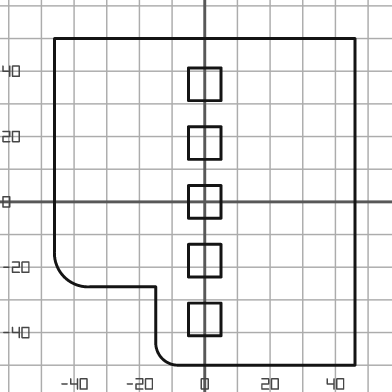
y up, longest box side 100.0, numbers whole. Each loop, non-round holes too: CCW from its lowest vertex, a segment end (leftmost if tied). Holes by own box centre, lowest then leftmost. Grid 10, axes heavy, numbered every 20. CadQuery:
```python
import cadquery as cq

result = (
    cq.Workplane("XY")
    .moveTo(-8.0, -50.0)
    .lineTo(46.0, -50.0)
    .lineTo(46.0, 50.0)
    .lineTo(-46.0, 50.0)
    .lineTo(-46.0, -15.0)
    .threePointArc((-43.0, -23.0), (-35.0, -26.0))
    .lineTo(-15.0, -26.0)
    .lineTo(-15.0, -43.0)
    .threePointArc((-13.0, -48.0), (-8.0, -50.0))
    .close()
    .moveTo(-5.0, -41.0)
    .lineTo(5.0, -41.0)
    .lineTo(5.0, -31.0)
    .lineTo(-5.0, -31.0)
    .close()
    .moveTo(-5.0, -23.0)
    .lineTo(5.0, -23.0)
    .lineTo(5.0, -13.0)
    .lineTo(-5.0, -13.0)
    .close()
    .moveTo(-5.0, -5.0)
    .lineTo(5.0, -5.0)
    .lineTo(5.0, 5.0)
    .lineTo(-5.0, 5.0)
    .close()
    .moveTo(-5.0, 13.0)
    .lineTo(5.0, 13.0)
    .lineTo(5.0, 23.0)
    .lineTo(-5.0, 23.0)
    .close()
    .moveTo(-5.0, 31.0)
    .lineTo(5.0, 31.0)
    .lineTo(5.0, 41.0)
    .lineTo(-5.0, 41.0)
    .close()
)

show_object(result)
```